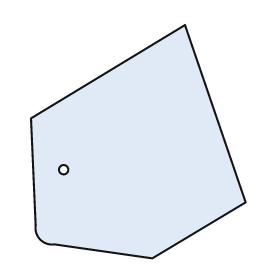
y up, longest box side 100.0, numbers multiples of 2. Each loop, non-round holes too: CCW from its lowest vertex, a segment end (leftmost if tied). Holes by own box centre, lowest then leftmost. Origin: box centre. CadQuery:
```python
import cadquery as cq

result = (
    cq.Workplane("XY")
    .moveTo(6.0, -50.0)
    .lineTo(46.0, -26.0)
    .lineTo(20.0, 50.0)
    .lineTo(-46.0, 10.0)
    .lineTo(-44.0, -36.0)
    .threePointArc((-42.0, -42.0), (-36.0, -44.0))
    .close()
    .moveTo(-32.0, -12.0)
    .circle(2.0)
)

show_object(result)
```